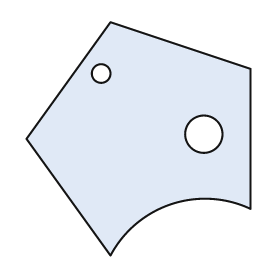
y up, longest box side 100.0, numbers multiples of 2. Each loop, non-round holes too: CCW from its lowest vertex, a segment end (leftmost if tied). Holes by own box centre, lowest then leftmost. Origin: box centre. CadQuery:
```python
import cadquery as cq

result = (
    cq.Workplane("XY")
    .moveTo(-12.0, -50.0)
    .threePointArc((14.0, -28.0), (48.0, -30.0))
    .lineTo(48.0, 30.0)
    .lineTo(-12.0, 50.0)
    .lineTo(-48.0, 0.0)
    .close()
    .moveTo(28.0, 2.0)
    .circle(8.0)
    .moveTo(-16.0, 28.0)
    .circle(4.0)
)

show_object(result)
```